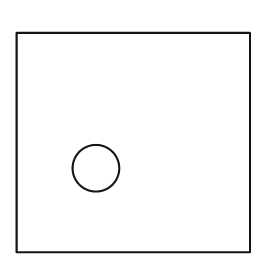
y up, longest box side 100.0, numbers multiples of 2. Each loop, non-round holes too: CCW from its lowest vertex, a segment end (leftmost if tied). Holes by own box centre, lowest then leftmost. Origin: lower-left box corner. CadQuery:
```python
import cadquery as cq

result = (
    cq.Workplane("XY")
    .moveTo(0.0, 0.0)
    .lineTo(100.0, 0.0)
    .lineTo(100.0, 94.0)
    .lineTo(0.0, 94.0)
    .close()
    .moveTo(34.0, 36.0)
    .circle(10.0)
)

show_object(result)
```